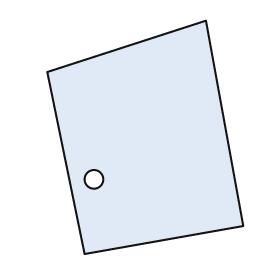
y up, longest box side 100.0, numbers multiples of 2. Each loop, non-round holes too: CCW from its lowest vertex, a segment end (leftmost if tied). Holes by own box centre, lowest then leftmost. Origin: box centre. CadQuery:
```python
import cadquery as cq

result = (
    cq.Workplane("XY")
    .moveTo(-26.0, -50.0)
    .lineTo(42.0, -38.0)
    .lineTo(26.0, 50.0)
    .lineTo(-42.0, 28.0)
    .close()
    .moveTo(-22.0, -18.0)
    .circle(4.0)
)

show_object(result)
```